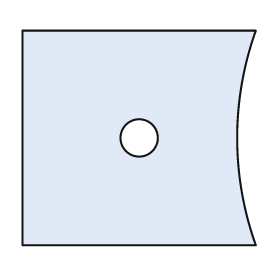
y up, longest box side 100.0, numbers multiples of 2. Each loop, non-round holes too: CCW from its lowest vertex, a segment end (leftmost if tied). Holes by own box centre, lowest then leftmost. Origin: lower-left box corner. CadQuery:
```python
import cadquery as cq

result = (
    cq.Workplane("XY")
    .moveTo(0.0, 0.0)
    .lineTo(100.0, 0.0)
    .threePointArc((92.0, 46.0), (100.0, 92.0))
    .lineTo(0.0, 92.0)
    .close()
    .moveTo(50.0, 46.0)
    .circle(8.0)
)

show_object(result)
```